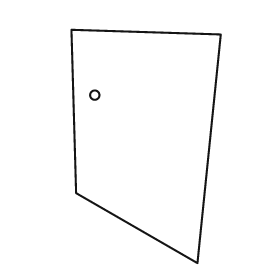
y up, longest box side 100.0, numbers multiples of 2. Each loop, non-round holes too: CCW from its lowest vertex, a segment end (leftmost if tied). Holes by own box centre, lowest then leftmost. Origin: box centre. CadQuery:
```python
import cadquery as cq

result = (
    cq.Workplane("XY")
    .moveTo(22.0, -50.0)
    .lineTo(32.0, 48.0)
    .lineTo(-32.0, 50.0)
    .lineTo(-30.0, -20.0)
    .close()
    .moveTo(-22.0, 22.0)
    .circle(2.0)
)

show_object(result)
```